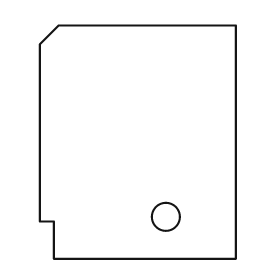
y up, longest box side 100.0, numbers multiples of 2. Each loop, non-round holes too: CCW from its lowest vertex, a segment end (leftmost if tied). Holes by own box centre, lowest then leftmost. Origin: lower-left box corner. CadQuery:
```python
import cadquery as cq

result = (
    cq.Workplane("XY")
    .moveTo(6.0, 0.0)
    .lineTo(84.0, 0.0)
    .lineTo(84.0, 100.0)
    .lineTo(8.0, 100.0)
    .lineTo(0.0, 92.0)
    .lineTo(0.0, 16.0)
    .lineTo(6.0, 16.0)
    .close()
    .moveTo(54.0, 18.0)
    .circle(6.0)
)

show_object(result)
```